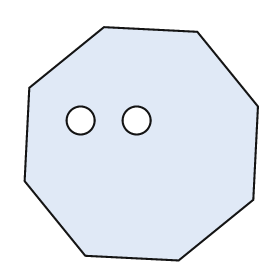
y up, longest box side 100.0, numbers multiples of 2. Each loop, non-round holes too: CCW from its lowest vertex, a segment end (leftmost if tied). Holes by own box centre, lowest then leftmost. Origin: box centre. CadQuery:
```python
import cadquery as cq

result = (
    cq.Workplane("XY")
    .moveTo(16.0, -50.0)
    .lineTo(48.0, -24.0)
    .lineTo(50.0, 16.0)
    .lineTo(24.0, 48.0)
    .lineTo(-16.0, 50.0)
    .lineTo(-48.0, 24.0)
    .lineTo(-50.0, -16.0)
    .lineTo(-24.0, -48.0)
    .close()
    .moveTo(-26.0, 10.0)
    .circle(6.0)
    .moveTo(-2.0, 10.0)
    .circle(6.0)
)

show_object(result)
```